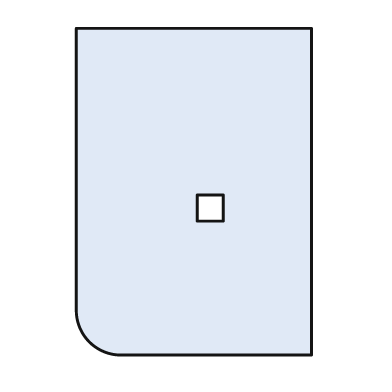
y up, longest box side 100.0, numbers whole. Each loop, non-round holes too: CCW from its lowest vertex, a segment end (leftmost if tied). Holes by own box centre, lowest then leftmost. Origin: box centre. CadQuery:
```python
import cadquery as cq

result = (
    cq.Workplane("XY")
    .moveTo(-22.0, -50.0)
    .lineTo(36.0, -50.0)
    .lineTo(36.0, 50.0)
    .lineTo(-36.0, 50.0)
    .lineTo(-36.0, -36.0)
    .threePointArc((-32.0, -46.0), (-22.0, -50.0))
    .close()
    .moveTo(1.0, -9.0)
    .lineTo(9.0, -9.0)
    .lineTo(9.0, -1.0)
    .lineTo(1.0, -1.0)
    .close()
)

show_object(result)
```